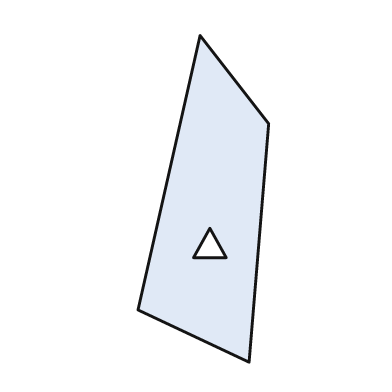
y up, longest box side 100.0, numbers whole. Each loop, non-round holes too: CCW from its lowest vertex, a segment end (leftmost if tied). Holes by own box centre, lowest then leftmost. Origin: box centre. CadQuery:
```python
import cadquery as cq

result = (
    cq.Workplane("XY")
    .moveTo(14.0, -50.0)
    .lineTo(20.0, 23.0)
    .lineTo(-1.0, 50.0)
    .lineTo(-20.0, -34.0)
    .close()
    .moveTo(-3.0, -18.0)
    .lineTo(7.0, -18.0)
    .lineTo(2.0, -9.0)
    .close()
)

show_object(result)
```